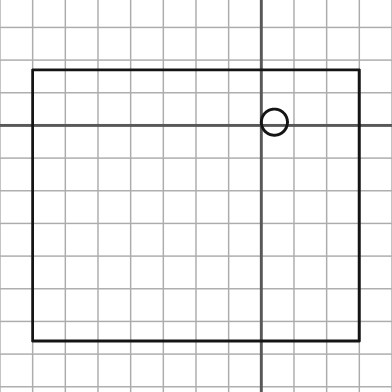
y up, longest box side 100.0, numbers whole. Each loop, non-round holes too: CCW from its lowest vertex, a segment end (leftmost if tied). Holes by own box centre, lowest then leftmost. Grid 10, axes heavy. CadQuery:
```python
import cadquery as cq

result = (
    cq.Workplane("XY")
    .moveTo(-70.0, -66.0)
    .lineTo(30.0, -66.0)
    .lineTo(30.0, 17.0)
    .lineTo(-70.0, 17.0)
    .close()
    .moveTo(4.0, 1.0)
    .circle(4.0)
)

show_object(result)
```